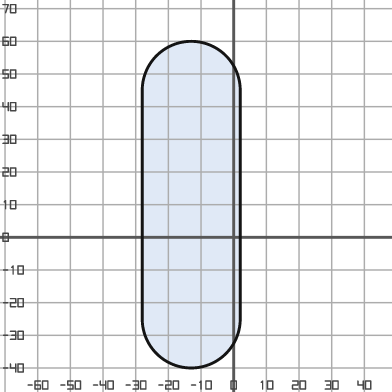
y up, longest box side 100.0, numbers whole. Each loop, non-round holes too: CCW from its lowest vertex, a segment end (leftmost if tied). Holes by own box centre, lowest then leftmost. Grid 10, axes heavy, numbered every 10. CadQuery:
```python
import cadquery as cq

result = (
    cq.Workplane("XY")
    .moveTo(-28.0, -25.0)
    .threePointArc((-13.0, -40.0), (2.0, -25.0))
    .lineTo(2.0, 45.0)
    .threePointArc((-13.0, 60.0), (-28.0, 45.0))
    .close()
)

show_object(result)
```